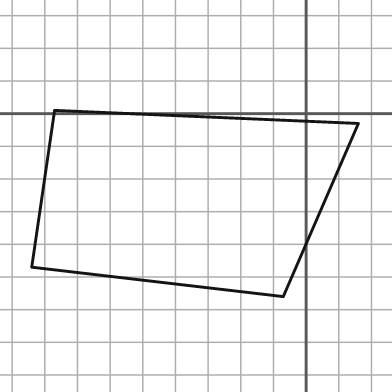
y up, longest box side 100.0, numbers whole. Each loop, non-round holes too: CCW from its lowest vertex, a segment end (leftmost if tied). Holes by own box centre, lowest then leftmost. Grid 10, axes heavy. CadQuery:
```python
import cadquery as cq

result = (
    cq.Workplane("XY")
    .moveTo(-7.0, -56.0)
    .lineTo(16.0, -3.0)
    .lineTo(-77.0, 1.0)
    .lineTo(-84.0, -47.0)
    .close()
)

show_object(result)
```